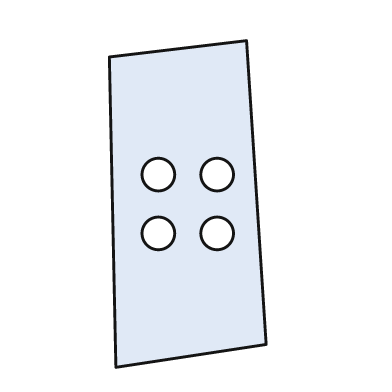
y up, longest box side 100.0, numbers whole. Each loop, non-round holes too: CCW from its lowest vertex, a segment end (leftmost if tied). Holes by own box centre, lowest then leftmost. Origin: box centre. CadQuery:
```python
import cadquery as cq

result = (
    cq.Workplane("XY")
    .moveTo(-22.0, -50.0)
    .lineTo(24.0, -43.0)
    .lineTo(18.0, 50.0)
    .lineTo(-24.0, 45.0)
    .close()
    .moveTo(-9.0, -9.0)
    .circle(5.0)
    .moveTo(9.0, -9.0)
    .circle(5.0)
    .moveTo(-9.0, 9.0)
    .circle(5.0)
    .moveTo(9.0, 9.0)
    .circle(5.0)
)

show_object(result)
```